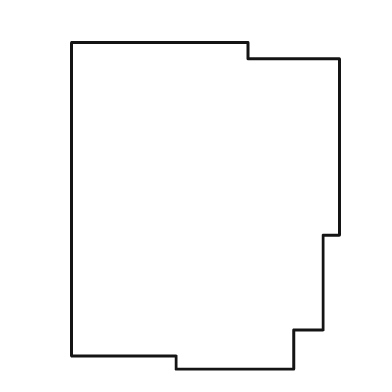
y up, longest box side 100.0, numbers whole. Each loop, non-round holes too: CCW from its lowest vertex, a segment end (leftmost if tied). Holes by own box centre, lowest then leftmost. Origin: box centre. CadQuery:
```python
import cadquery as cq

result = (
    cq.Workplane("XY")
    .moveTo(-9.0, -50.0)
    .lineTo(27.0, -50.0)
    .lineTo(27.0, -38.0)
    .lineTo(36.0, -38.0)
    .lineTo(36.0, -9.0)
    .lineTo(41.0, -9.0)
    .lineTo(41.0, 45.0)
    .lineTo(13.0, 45.0)
    .lineTo(13.0, 50.0)
    .lineTo(-41.0, 50.0)
    .lineTo(-41.0, -46.0)
    .lineTo(-9.0, -46.0)
    .close()
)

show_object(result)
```